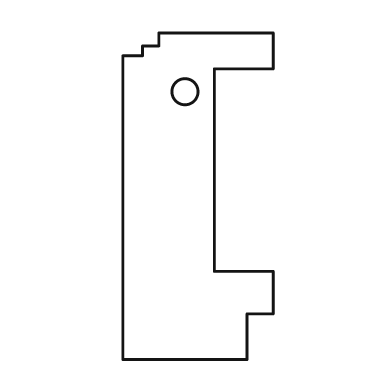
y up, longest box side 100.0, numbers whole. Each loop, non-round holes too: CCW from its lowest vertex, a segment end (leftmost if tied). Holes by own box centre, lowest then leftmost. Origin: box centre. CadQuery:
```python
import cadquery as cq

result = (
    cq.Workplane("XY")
    .moveTo(-23.0, -50.0)
    .lineTo(15.0, -50.0)
    .lineTo(15.0, -36.0)
    .lineTo(23.0, -36.0)
    .lineTo(23.0, -23.0)
    .lineTo(5.0, -23.0)
    .lineTo(5.0, 39.0)
    .lineTo(23.0, 39.0)
    .lineTo(23.0, 50.0)
    .lineTo(-12.0, 50.0)
    .lineTo(-12.0, 46.0)
    .lineTo(-17.0, 46.0)
    .lineTo(-17.0, 43.0)
    .lineTo(-23.0, 43.0)
    .close()
    .moveTo(-4.0, 32.0)
    .circle(4.0)
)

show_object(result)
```